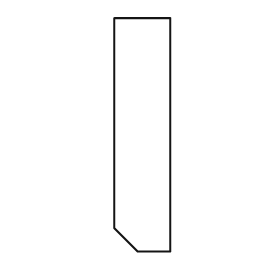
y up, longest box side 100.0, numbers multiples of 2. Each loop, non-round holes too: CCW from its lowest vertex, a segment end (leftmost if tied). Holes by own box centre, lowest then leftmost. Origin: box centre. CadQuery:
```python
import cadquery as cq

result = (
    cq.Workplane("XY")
    .moveTo(-2.0, -50.0)
    .lineTo(12.0, -50.0)
    .lineTo(12.0, 50.0)
    .lineTo(-12.0, 50.0)
    .lineTo(-12.0, -40.0)
    .close()
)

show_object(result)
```